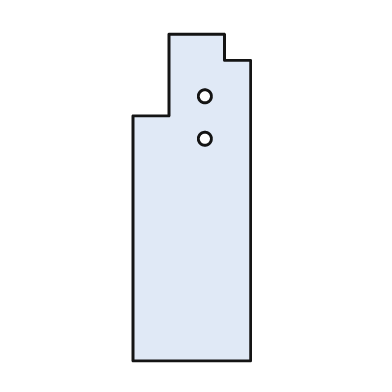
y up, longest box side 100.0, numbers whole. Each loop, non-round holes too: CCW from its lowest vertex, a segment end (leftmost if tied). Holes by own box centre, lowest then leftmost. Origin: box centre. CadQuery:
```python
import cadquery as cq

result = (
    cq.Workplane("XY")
    .moveTo(-18.0, -50.0)
    .lineTo(18.0, -50.0)
    .lineTo(18.0, 42.0)
    .lineTo(10.0, 42.0)
    .lineTo(10.0, 50.0)
    .lineTo(-7.0, 50.0)
    .lineTo(-7.0, 25.0)
    .lineTo(-18.0, 25.0)
    .close()
    .moveTo(4.0, 18.0)
    .circle(2.0)
    .moveTo(4.0, 31.0)
    .circle(2.0)
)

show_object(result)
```